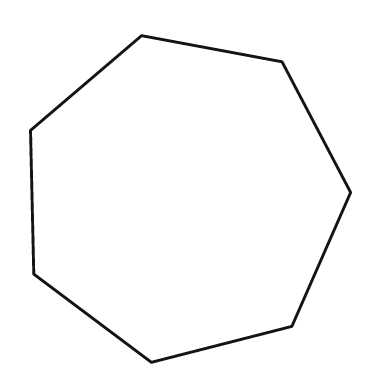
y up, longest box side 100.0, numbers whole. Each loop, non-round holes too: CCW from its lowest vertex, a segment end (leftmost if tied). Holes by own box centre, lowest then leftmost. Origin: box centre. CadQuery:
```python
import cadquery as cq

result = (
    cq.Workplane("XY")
    .moveTo(-12.0, -50.0)
    .lineTo(31.0, -39.0)
    .lineTo(49.0, 2.0)
    .lineTo(28.0, 42.0)
    .lineTo(-15.0, 50.0)
    .lineTo(-49.0, 21.0)
    .lineTo(-48.0, -23.0)
    .close()
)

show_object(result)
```